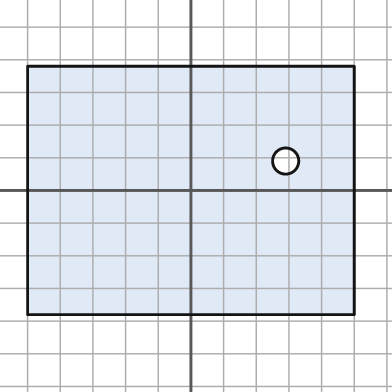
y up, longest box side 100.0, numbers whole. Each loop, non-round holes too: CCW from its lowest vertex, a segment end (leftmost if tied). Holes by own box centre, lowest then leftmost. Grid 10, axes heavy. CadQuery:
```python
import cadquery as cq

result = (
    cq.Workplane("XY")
    .moveTo(-50.0, -38.0)
    .lineTo(50.0, -38.0)
    .lineTo(50.0, 38.0)
    .lineTo(-50.0, 38.0)
    .close()
    .moveTo(29.0, 9.0)
    .circle(4.0)
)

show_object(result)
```